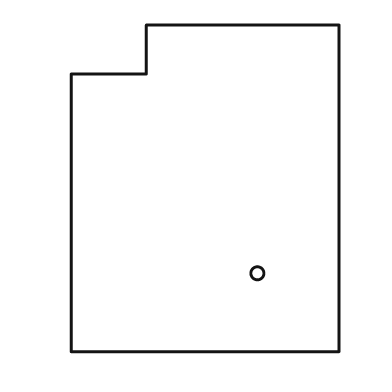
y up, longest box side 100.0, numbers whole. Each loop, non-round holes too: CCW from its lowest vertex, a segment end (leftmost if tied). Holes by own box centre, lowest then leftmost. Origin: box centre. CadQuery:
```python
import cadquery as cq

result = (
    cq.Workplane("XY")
    .moveTo(-41.0, -50.0)
    .lineTo(41.0, -50.0)
    .lineTo(41.0, 50.0)
    .lineTo(-18.0, 50.0)
    .lineTo(-18.0, 35.0)
    .lineTo(-41.0, 35.0)
    .close()
    .moveTo(16.0, -26.0)
    .circle(2.0)
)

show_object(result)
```